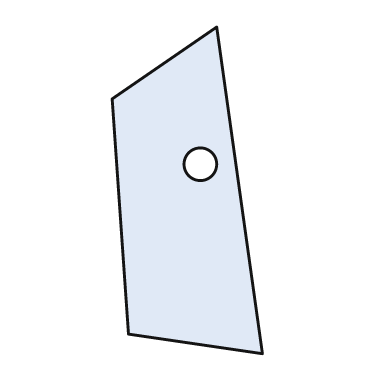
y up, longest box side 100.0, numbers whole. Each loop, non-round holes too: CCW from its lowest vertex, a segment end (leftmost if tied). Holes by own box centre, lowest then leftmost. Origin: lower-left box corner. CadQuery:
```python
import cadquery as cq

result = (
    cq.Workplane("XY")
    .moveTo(46.0, 0.0)
    .lineTo(32.0, 100.0)
    .lineTo(0.0, 78.0)
    .lineTo(5.0, 6.0)
    .close()
    .moveTo(27.0, 58.0)
    .circle(5.0)
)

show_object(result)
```